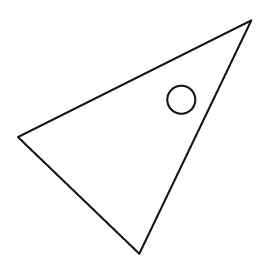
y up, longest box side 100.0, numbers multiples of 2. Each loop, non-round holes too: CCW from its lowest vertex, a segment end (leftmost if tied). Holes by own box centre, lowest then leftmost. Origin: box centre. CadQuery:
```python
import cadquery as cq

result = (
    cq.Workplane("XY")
    .moveTo(2.0, -50.0)
    .lineTo(50.0, 50.0)
    .lineTo(-50.0, 0.0)
    .close()
    .moveTo(20.0, 16.0)
    .circle(6.0)
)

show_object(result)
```